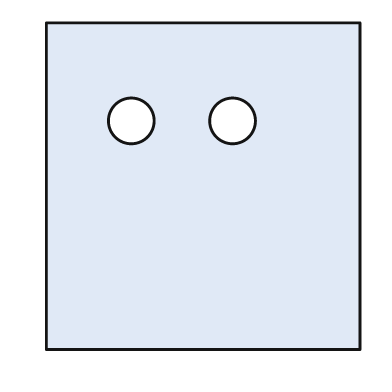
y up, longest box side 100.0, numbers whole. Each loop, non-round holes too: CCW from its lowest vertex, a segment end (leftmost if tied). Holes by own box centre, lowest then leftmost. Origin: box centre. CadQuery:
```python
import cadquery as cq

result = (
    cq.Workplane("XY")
    .moveTo(-48.0, -50.0)
    .lineTo(48.0, -50.0)
    .lineTo(48.0, 50.0)
    .lineTo(-48.0, 50.0)
    .close()
    .moveTo(-22.0, 20.0)
    .circle(7.0)
    .moveTo(9.0, 20.0)
    .circle(7.0)
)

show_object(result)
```